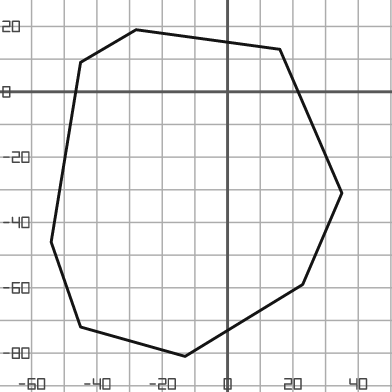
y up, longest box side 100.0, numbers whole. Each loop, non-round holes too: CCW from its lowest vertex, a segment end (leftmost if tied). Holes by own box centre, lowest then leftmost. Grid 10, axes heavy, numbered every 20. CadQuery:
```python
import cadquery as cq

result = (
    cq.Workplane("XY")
    .moveTo(-13.0, -81.0)
    .lineTo(23.0, -59.0)
    .lineTo(35.0, -31.0)
    .lineTo(16.0, 13.0)
    .lineTo(-28.0, 19.0)
    .lineTo(-45.0, 9.0)
    .lineTo(-54.0, -46.0)
    .lineTo(-45.0, -72.0)
    .close()
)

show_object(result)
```